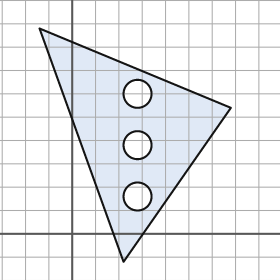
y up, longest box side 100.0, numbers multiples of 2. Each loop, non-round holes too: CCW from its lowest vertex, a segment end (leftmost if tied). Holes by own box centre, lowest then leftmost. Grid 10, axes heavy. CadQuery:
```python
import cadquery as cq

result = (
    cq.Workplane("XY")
    .moveTo(22.0, -12.0)
    .lineTo(68.0, 54.0)
    .lineTo(-14.0, 88.0)
    .close()
    .moveTo(28.0, 16.0)
    .circle(6.0)
    .moveTo(28.0, 38.0)
    .circle(6.0)
    .moveTo(28.0, 60.0)
    .circle(6.0)
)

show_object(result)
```